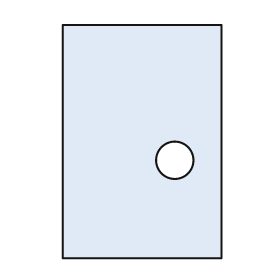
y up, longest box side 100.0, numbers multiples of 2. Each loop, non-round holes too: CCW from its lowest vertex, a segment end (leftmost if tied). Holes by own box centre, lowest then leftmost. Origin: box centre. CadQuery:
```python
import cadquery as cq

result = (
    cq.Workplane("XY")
    .moveTo(-34.0, -50.0)
    .lineTo(34.0, -50.0)
    .lineTo(34.0, 50.0)
    .lineTo(-34.0, 50.0)
    .close()
    .moveTo(14.0, -8.0)
    .circle(8.0)
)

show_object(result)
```